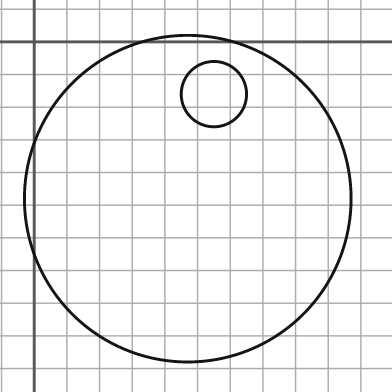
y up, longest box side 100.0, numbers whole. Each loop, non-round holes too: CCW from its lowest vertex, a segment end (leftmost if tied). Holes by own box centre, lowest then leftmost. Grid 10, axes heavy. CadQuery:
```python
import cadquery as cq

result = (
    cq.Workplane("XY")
    .moveTo(47.0, -48.0)
    .circle(50.0)
    .moveTo(55.0, -16.0)
    .circle(10.0)
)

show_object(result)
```